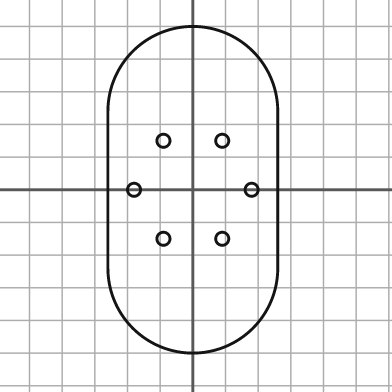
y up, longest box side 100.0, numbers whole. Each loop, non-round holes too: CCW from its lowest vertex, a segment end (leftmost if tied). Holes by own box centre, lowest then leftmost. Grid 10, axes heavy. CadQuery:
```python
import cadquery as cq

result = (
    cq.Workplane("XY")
    .moveTo(-26.0, -24.0)
    .threePointArc((0.0, -50.0), (26.0, -24.0))
    .lineTo(26.0, 24.0)
    .threePointArc((0.0, 50.0), (-26.0, 24.0))
    .close()
    .moveTo(-9.0, -15.0)
    .circle(2.0)
    .moveTo(9.0, -15.0)
    .circle(2.0)
    .moveTo(-18.0, 0.0)
    .circle(2.0)
    .moveTo(18.0, 0.0)
    .circle(2.0)
    .moveTo(-9.0, 15.0)
    .circle(2.0)
    .moveTo(9.0, 15.0)
    .circle(2.0)
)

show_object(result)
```